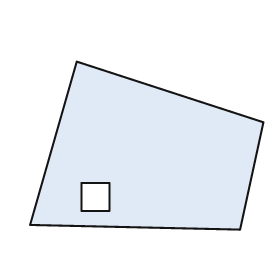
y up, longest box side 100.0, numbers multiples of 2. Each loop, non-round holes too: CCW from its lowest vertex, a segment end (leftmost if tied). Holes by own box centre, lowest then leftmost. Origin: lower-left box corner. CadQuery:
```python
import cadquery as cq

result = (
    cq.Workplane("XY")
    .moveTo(90.0, 0.0)
    .lineTo(100.0, 46.0)
    .lineTo(20.0, 72.0)
    .lineTo(0.0, 2.0)
    .close()
    .moveTo(22.0, 8.0)
    .lineTo(34.0, 8.0)
    .lineTo(34.0, 20.0)
    .lineTo(22.0, 20.0)
    .close()
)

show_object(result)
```